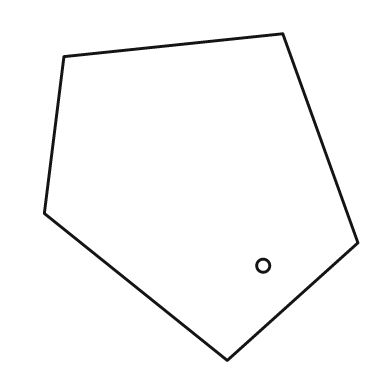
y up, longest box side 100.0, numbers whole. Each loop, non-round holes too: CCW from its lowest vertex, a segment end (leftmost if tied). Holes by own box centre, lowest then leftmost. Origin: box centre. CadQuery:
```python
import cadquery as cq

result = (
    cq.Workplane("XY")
    .moveTo(8.0, -50.0)
    .lineTo(48.0, -14.0)
    .lineTo(25.0, 50.0)
    .lineTo(-42.0, 43.0)
    .lineTo(-48.0, -5.0)
    .close()
    .moveTo(19.0, -21.0)
    .circle(2.0)
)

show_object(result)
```